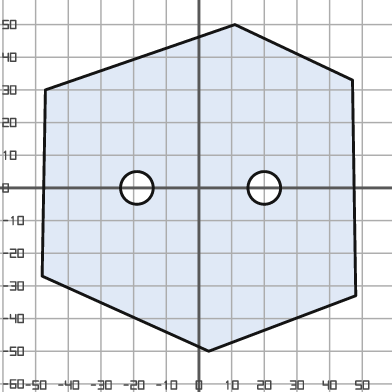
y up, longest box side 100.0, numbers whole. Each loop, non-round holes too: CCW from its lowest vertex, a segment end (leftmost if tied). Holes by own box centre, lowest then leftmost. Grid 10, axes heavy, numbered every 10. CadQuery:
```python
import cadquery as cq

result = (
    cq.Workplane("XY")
    .moveTo(3.0, -50.0)
    .lineTo(48.0, -33.0)
    .lineTo(47.0, 33.0)
    .lineTo(11.0, 50.0)
    .lineTo(-47.0, 30.0)
    .lineTo(-48.0, -27.0)
    .close()
    .moveTo(-19.0, 0.0)
    .circle(5.0)
    .moveTo(20.0, 0.0)
    .circle(5.0)
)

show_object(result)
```